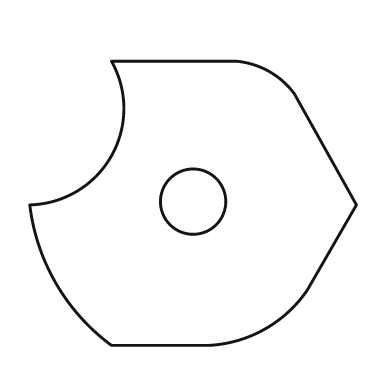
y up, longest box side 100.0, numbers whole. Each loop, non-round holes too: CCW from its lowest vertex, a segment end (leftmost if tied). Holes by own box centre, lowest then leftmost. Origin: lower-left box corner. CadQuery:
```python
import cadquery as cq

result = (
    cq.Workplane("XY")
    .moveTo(25.0, 0.0)
    .lineTo(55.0, 0.0)
    .threePointArc((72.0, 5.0), (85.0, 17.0))
    .lineTo(100.0, 43.0)
    .lineTo(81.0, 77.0)
    .threePointArc((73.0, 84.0), (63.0, 87.0))
    .lineTo(25.0, 87.0)
    .threePointArc((25.0, 58.0), (0.0, 43.0))
    .threePointArc((8.0, 19.0), (25.0, 0.0))
    .close()
    .moveTo(50.0, 44.0)
    .circle(10.0)
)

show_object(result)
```